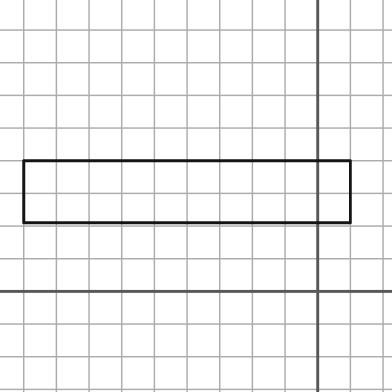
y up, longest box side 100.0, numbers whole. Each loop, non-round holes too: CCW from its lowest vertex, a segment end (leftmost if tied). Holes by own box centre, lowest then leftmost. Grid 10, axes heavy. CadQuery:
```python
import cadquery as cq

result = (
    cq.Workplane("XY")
    .moveTo(-90.0, 21.0)
    .lineTo(10.0, 21.0)
    .lineTo(10.0, 40.0)
    .lineTo(-90.0, 40.0)
    .close()
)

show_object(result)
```